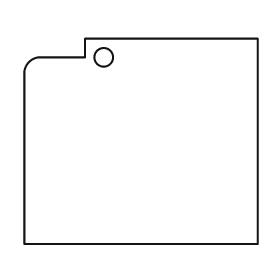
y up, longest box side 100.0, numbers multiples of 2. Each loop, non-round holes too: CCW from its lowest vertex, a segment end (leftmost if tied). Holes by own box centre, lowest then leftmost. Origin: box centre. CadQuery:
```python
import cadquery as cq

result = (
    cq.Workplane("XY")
    .moveTo(-50.0, -44.0)
    .lineTo(50.0, -44.0)
    .lineTo(50.0, 44.0)
    .lineTo(-24.0, 44.0)
    .lineTo(-24.0, 36.0)
    .lineTo(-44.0, 36.0)
    .threePointArc((-48.0, 34.0), (-50.0, 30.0))
    .close()
    .moveTo(-16.0, 36.0)
    .circle(4.0)
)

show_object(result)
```